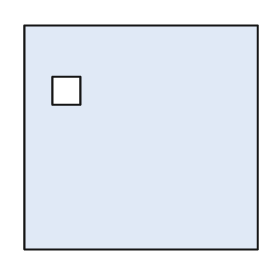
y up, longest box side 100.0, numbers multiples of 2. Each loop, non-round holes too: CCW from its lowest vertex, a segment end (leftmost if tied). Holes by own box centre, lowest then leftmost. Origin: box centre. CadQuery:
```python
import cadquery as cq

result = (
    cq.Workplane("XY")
    .moveTo(-50.0, -48.0)
    .lineTo(50.0, -48.0)
    .lineTo(50.0, 48.0)
    .lineTo(-50.0, 48.0)
    .close()
    .moveTo(-38.0, 14.0)
    .lineTo(-26.0, 14.0)
    .lineTo(-26.0, 26.0)
    .lineTo(-38.0, 26.0)
    .close()
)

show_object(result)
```